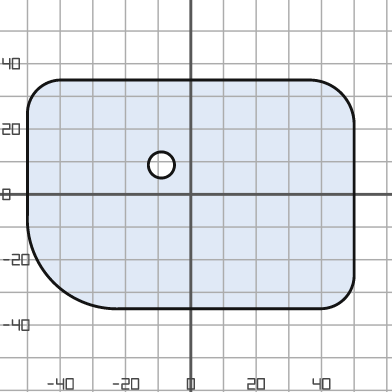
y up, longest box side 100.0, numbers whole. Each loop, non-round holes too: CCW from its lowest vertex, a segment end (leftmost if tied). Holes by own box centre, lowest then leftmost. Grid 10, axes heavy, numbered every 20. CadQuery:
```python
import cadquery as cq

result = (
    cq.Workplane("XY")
    .moveTo(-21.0, -35.0)
    .lineTo(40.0, -35.0)
    .threePointArc((47.0, -32.0), (50.0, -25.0))
    .lineTo(50.0, 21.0)
    .threePointArc((46.0, 31.0), (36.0, 35.0))
    .lineTo(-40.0, 35.0)
    .threePointArc((-47.0, 32.0), (-50.0, 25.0))
    .lineTo(-50.0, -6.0)
    .threePointArc((-42.0, -27.0), (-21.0, -35.0))
    .close()
    .moveTo(-9.0, 9.0)
    .circle(4.0)
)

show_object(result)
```